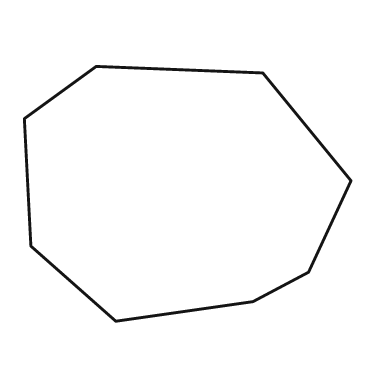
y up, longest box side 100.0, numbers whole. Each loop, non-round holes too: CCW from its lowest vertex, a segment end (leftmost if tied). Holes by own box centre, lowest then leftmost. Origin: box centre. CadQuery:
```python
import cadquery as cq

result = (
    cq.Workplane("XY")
    .moveTo(-22.0, -39.0)
    .lineTo(20.0, -33.0)
    .lineTo(37.0, -24.0)
    .lineTo(50.0, 4.0)
    .lineTo(23.0, 37.0)
    .lineTo(-28.0, 39.0)
    .lineTo(-50.0, 23.0)
    .lineTo(-48.0, -16.0)
    .close()
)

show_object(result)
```